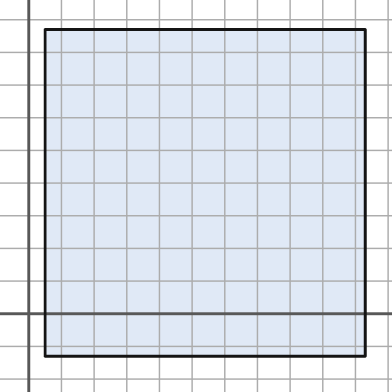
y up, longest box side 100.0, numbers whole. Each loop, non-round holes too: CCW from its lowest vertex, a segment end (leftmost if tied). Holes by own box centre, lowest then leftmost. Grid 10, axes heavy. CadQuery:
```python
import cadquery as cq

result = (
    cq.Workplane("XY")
    .moveTo(5.0, -13.0)
    .lineTo(103.0, -13.0)
    .lineTo(103.0, 87.0)
    .lineTo(5.0, 87.0)
    .close()
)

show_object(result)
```